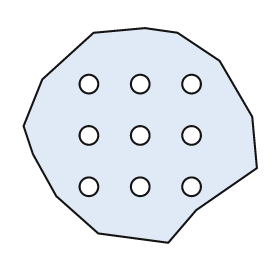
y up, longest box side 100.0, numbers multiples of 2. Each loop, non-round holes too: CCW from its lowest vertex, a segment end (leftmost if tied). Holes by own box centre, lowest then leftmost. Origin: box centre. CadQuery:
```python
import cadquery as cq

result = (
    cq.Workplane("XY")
    .moveTo(12.0, -46.0)
    .lineTo(24.0, -32.0)
    .lineTo(50.0, -14.0)
    .lineTo(48.0, 8.0)
    .lineTo(34.0, 32.0)
    .lineTo(16.0, 44.0)
    .lineTo(2.0, 46.0)
    .lineTo(-20.0, 44.0)
    .lineTo(-42.0, 24.0)
    .lineTo(-50.0, 4.0)
    .lineTo(-46.0, -8.0)
    .lineTo(-36.0, -26.0)
    .lineTo(-18.0, -42.0)
    .close()
    .moveTo(-22.0, -22.0)
    .circle(4.0)
    .moveTo(0.0, -22.0)
    .circle(4.0)
    .moveTo(22.0, -22.0)
    .circle(4.0)
    .moveTo(-22.0, 0.0)
    .circle(4.0)
    .moveTo(0.0, 0.0)
    .circle(4.0)
    .moveTo(22.0, 0.0)
    .circle(4.0)
    .moveTo(-22.0, 22.0)
    .circle(4.0)
    .moveTo(0.0, 22.0)
    .circle(4.0)
    .moveTo(22.0, 22.0)
    .circle(4.0)
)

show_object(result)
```